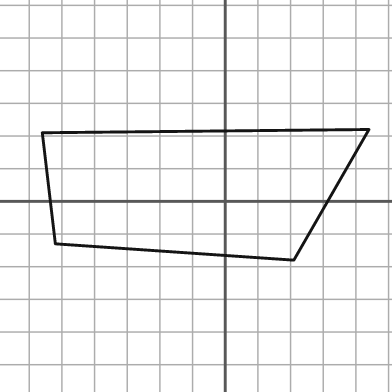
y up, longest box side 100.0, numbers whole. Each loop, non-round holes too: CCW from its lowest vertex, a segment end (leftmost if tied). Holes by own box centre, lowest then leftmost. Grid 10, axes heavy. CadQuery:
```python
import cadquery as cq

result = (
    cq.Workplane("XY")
    .moveTo(21.0, -18.0)
    .lineTo(44.0, 22.0)
    .lineTo(-56.0, 21.0)
    .lineTo(-52.0, -13.0)
    .close()
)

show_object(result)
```